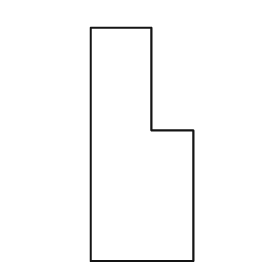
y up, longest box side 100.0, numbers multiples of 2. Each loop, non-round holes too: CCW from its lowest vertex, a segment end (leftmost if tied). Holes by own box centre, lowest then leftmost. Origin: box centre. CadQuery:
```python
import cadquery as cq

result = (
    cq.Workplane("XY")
    .moveTo(-22.0, -50.0)
    .lineTo(22.0, -50.0)
    .lineTo(22.0, 6.0)
    .lineTo(4.0, 6.0)
    .lineTo(4.0, 50.0)
    .lineTo(-22.0, 50.0)
    .close()
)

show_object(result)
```